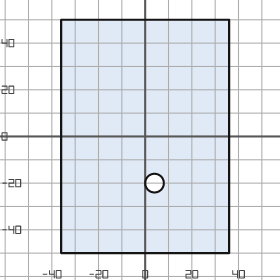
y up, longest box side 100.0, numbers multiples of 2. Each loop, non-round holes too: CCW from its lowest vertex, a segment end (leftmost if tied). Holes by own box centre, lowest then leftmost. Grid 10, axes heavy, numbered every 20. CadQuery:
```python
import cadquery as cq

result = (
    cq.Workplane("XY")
    .moveTo(-36.0, -50.0)
    .lineTo(36.0, -50.0)
    .lineTo(36.0, 50.0)
    .lineTo(-36.0, 50.0)
    .close()
    .moveTo(4.0, -20.0)
    .circle(4.0)
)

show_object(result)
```